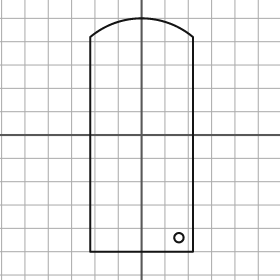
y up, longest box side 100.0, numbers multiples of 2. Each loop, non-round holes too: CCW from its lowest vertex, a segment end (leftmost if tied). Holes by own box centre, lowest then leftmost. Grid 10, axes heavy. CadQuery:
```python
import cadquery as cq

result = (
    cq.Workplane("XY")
    .moveTo(-22.0, -50.0)
    .lineTo(22.0, -50.0)
    .lineTo(22.0, 42.0)
    .threePointArc((0.0, 50.0), (-22.0, 42.0))
    .close()
    .moveTo(16.0, -44.0)
    .circle(2.0)
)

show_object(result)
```